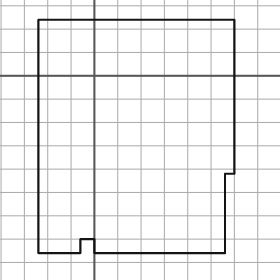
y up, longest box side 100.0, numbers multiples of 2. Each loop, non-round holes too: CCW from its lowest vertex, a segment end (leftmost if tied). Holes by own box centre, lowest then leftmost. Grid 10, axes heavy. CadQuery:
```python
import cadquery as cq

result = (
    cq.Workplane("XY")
    .moveTo(-24.0, -76.0)
    .lineTo(-6.0, -76.0)
    .lineTo(-6.0, -70.0)
    .lineTo(0.0, -70.0)
    .lineTo(0.0, -76.0)
    .lineTo(56.0, -76.0)
    .lineTo(56.0, -42.0)
    .lineTo(60.0, -42.0)
    .lineTo(60.0, 24.0)
    .lineTo(-24.0, 24.0)
    .close()
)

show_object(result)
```